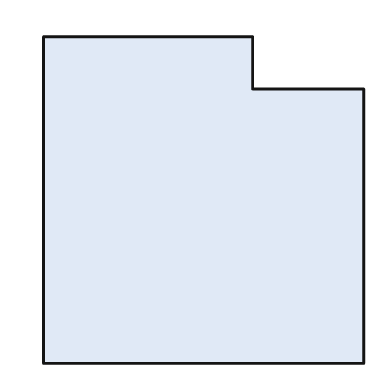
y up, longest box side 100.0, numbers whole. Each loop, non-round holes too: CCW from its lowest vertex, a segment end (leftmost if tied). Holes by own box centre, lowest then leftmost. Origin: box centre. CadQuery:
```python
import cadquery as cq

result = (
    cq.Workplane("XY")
    .moveTo(-49.0, -50.0)
    .lineTo(49.0, -50.0)
    .lineTo(49.0, 34.0)
    .lineTo(15.0, 34.0)
    .lineTo(15.0, 50.0)
    .lineTo(-49.0, 50.0)
    .close()
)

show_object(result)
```